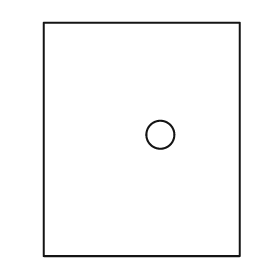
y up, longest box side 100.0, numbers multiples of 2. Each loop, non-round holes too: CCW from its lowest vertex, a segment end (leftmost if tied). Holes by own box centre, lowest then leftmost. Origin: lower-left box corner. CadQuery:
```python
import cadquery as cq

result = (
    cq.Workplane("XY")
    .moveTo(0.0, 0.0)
    .lineTo(84.0, 0.0)
    .lineTo(84.0, 100.0)
    .lineTo(0.0, 100.0)
    .close()
    .moveTo(50.0, 52.0)
    .circle(6.0)
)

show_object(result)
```